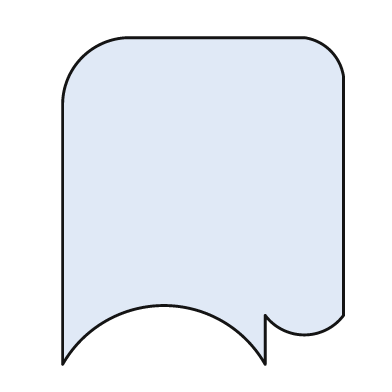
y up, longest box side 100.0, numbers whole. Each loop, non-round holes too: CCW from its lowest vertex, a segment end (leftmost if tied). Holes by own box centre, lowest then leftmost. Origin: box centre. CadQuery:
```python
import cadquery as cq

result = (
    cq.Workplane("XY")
    .moveTo(-43.0, -50.0)
    .threePointArc((-12.0, -32.0), (19.0, -50.0))
    .lineTo(19.0, -35.0)
    .threePointArc((31.0, -41.0), (43.0, -35.0))
    .lineTo(43.0, 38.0)
    .threePointArc((39.0, 46.0), (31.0, 50.0))
    .lineTo(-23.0, 50.0)
    .threePointArc((-37.0, 44.0), (-43.0, 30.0))
    .close()
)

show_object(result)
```